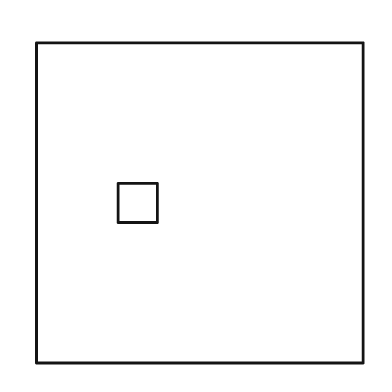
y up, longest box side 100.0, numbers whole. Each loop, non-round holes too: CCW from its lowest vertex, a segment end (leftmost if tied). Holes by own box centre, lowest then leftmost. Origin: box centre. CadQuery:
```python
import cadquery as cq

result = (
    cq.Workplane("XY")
    .moveTo(-50.0, -49.0)
    .lineTo(50.0, -49.0)
    .lineTo(50.0, 49.0)
    .lineTo(-50.0, 49.0)
    .close()
    .moveTo(-25.0, -6.0)
    .lineTo(-13.0, -6.0)
    .lineTo(-13.0, 6.0)
    .lineTo(-25.0, 6.0)
    .close()
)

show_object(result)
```